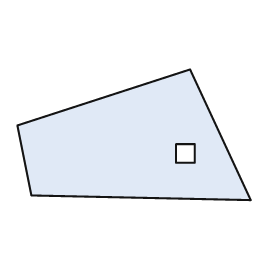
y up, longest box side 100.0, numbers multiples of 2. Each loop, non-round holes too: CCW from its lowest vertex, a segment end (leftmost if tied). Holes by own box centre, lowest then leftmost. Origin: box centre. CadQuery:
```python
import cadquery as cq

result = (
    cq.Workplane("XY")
    .moveTo(50.0, -28.0)
    .lineTo(24.0, 28.0)
    .lineTo(-50.0, 4.0)
    .lineTo(-44.0, -26.0)
    .close()
    .moveTo(18.0, -12.0)
    .lineTo(26.0, -12.0)
    .lineTo(26.0, -4.0)
    .lineTo(18.0, -4.0)
    .close()
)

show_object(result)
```